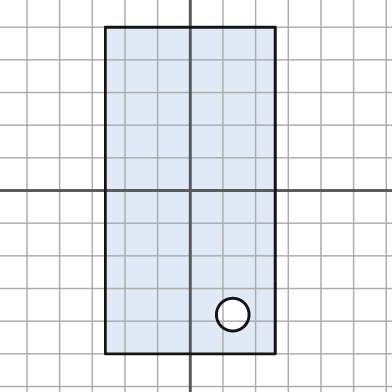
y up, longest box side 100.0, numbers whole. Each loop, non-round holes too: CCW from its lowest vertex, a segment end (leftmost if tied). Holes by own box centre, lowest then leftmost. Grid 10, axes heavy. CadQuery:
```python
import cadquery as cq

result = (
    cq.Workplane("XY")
    .moveTo(-26.0, -50.0)
    .lineTo(26.0, -50.0)
    .lineTo(26.0, 50.0)
    .lineTo(-26.0, 50.0)
    .close()
    .moveTo(13.0, -38.0)
    .circle(5.0)
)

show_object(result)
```